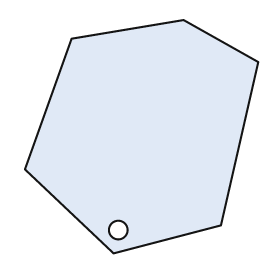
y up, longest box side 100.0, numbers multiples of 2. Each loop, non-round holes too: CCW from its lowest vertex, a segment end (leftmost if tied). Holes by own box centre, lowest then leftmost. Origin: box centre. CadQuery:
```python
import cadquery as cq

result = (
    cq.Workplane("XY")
    .moveTo(-12.0, -50.0)
    .lineTo(34.0, -38.0)
    .lineTo(50.0, 32.0)
    .lineTo(18.0, 50.0)
    .lineTo(-30.0, 42.0)
    .lineTo(-50.0, -14.0)
    .close()
    .moveTo(-10.0, -40.0)
    .circle(4.0)
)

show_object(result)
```